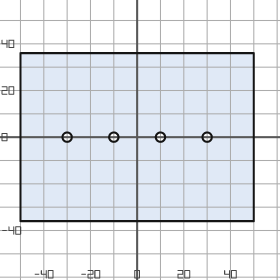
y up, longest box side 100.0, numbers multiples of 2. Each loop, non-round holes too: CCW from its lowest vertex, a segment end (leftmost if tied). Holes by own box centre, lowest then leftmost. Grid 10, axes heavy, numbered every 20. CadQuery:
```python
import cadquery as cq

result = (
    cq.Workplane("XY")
    .moveTo(-50.0, -36.0)
    .lineTo(50.0, -36.0)
    .lineTo(50.0, 36.0)
    .lineTo(-50.0, 36.0)
    .close()
    .moveTo(-30.0, 0.0)
    .circle(2.0)
    .moveTo(-10.0, 0.0)
    .circle(2.0)
    .moveTo(10.0, 0.0)
    .circle(2.0)
    .moveTo(30.0, 0.0)
    .circle(2.0)
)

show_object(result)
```